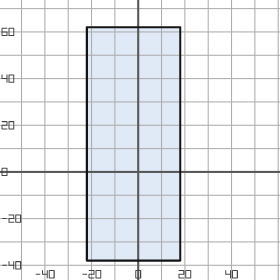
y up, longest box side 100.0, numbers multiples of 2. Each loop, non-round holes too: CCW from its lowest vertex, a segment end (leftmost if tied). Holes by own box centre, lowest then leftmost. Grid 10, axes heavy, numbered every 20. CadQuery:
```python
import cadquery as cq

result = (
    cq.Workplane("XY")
    .moveTo(-22.0, -38.0)
    .lineTo(18.0, -38.0)
    .lineTo(18.0, 62.0)
    .lineTo(-22.0, 62.0)
    .close()
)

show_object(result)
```